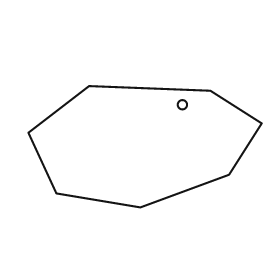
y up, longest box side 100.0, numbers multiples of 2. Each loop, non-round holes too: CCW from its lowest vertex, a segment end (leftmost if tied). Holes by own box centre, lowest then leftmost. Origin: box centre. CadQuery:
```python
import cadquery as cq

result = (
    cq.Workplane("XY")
    .moveTo(-2.0, -26.0)
    .lineTo(36.0, -12.0)
    .lineTo(50.0, 10.0)
    .lineTo(28.0, 24.0)
    .lineTo(-24.0, 26.0)
    .lineTo(-50.0, 6.0)
    .lineTo(-38.0, -20.0)
    .close()
    .moveTo(16.0, 18.0)
    .circle(2.0)
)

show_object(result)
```